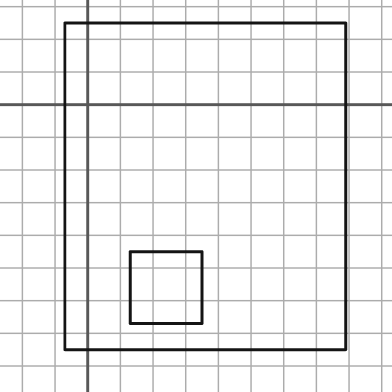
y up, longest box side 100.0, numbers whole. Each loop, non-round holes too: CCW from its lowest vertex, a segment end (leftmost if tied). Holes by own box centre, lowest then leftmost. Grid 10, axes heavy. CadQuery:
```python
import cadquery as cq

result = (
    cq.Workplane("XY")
    .moveTo(-7.0, -75.0)
    .lineTo(79.0, -75.0)
    .lineTo(79.0, 25.0)
    .lineTo(-7.0, 25.0)
    .close()
    .moveTo(13.0, -67.0)
    .lineTo(35.0, -67.0)
    .lineTo(35.0, -45.0)
    .lineTo(13.0, -45.0)
    .close()
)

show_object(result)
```